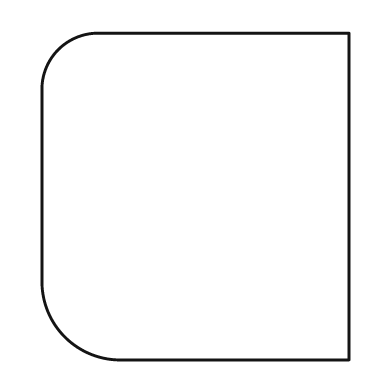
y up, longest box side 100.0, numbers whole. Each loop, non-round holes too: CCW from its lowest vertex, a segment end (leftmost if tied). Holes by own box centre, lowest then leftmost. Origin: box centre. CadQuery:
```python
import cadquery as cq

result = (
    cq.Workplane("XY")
    .moveTo(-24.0, -50.0)
    .lineTo(47.0, -50.0)
    .lineTo(47.0, 50.0)
    .lineTo(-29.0, 50.0)
    .threePointArc((-42.0, 45.0), (-47.0, 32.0))
    .lineTo(-47.0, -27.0)
    .threePointArc((-40.0, -43.0), (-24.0, -50.0))
    .close()
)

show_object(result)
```